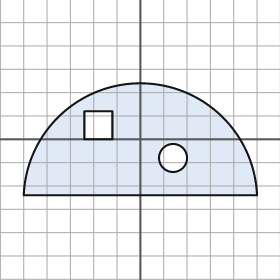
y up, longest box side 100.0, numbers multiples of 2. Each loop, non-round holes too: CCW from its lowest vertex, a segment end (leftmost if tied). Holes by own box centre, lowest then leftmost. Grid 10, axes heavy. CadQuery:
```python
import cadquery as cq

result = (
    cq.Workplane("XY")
    .moveTo(-50.0, -24.0)
    .lineTo(50.0, -24.0)
    .threePointArc((0.0, 24.0), (-50.0, -24.0))
    .close()
    .moveTo(14.0, -8.0)
    .circle(6.0)
    .moveTo(-24.0, 0.0)
    .lineTo(-12.0, 0.0)
    .lineTo(-12.0, 12.0)
    .lineTo(-24.0, 12.0)
    .close()
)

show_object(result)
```